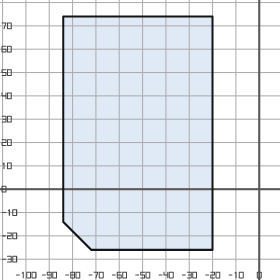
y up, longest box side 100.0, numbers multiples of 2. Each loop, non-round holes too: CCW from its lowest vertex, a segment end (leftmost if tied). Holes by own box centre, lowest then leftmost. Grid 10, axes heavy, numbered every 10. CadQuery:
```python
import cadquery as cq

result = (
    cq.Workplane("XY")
    .moveTo(-72.0, -26.0)
    .lineTo(-20.0, -26.0)
    .lineTo(-20.0, 74.0)
    .lineTo(-84.0, 74.0)
    .lineTo(-84.0, -14.0)
    .close()
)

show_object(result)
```